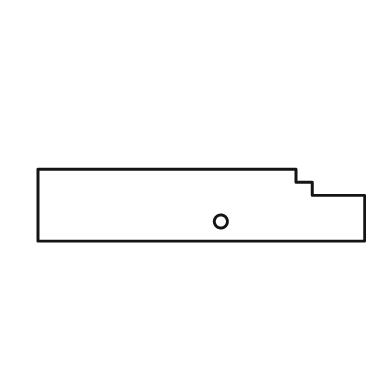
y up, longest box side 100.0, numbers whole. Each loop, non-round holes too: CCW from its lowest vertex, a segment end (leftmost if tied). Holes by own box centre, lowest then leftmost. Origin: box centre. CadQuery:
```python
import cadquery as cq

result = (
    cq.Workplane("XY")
    .moveTo(-50.0, -11.0)
    .lineTo(50.0, -11.0)
    .lineTo(50.0, 3.0)
    .lineTo(34.0, 3.0)
    .lineTo(34.0, 7.0)
    .lineTo(29.0, 7.0)
    .lineTo(29.0, 11.0)
    .lineTo(-50.0, 11.0)
    .close()
    .moveTo(6.0, -5.0)
    .circle(2.0)
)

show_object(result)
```